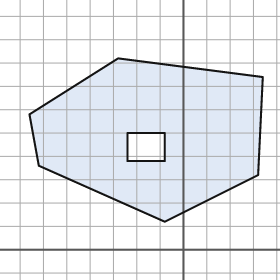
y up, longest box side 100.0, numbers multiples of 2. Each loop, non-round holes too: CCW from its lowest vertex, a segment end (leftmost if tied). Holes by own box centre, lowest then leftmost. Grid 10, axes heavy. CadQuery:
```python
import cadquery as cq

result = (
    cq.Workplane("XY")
    .moveTo(-8.0, 12.0)
    .lineTo(32.0, 32.0)
    .lineTo(34.0, 74.0)
    .lineTo(-28.0, 82.0)
    .lineTo(-66.0, 58.0)
    .lineTo(-62.0, 36.0)
    .close()
    .moveTo(-24.0, 38.0)
    .lineTo(-8.0, 38.0)
    .lineTo(-8.0, 50.0)
    .lineTo(-24.0, 50.0)
    .close()
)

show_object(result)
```